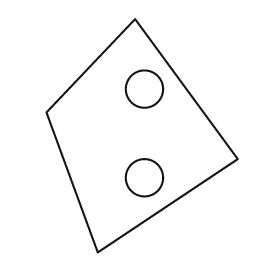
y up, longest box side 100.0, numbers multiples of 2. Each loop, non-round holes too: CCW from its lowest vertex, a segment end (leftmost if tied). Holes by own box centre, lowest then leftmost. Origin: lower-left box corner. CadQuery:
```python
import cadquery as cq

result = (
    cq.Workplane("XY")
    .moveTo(22.0, 0.0)
    .lineTo(82.0, 40.0)
    .lineTo(38.0, 100.0)
    .lineTo(0.0, 60.0)
    .close()
    .moveTo(42.0, 32.0)
    .circle(8.0)
    .moveTo(42.0, 70.0)
    .circle(8.0)
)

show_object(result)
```